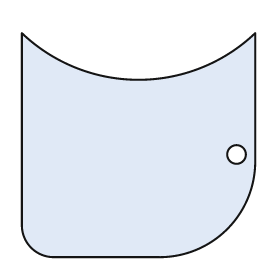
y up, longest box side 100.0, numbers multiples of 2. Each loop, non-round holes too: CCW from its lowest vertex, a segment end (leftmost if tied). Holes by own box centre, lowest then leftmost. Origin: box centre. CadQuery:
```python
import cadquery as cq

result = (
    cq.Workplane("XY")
    .moveTo(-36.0, -48.0)
    .lineTo(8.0, -48.0)
    .threePointArc((38.0, -36.0), (50.0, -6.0))
    .lineTo(50.0, 48.0)
    .threePointArc((0.0, 28.0), (-50.0, 48.0))
    .lineTo(-50.0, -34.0)
    .threePointArc((-46.0, -44.0), (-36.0, -48.0))
    .close()
    .moveTo(42.0, -4.0)
    .circle(4.0)
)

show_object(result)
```